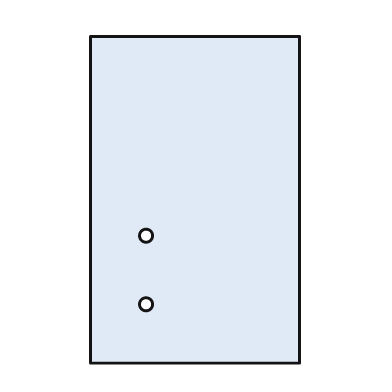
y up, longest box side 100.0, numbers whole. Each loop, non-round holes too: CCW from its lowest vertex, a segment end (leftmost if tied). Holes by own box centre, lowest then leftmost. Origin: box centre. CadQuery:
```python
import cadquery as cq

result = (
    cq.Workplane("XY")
    .moveTo(-32.0, -50.0)
    .lineTo(32.0, -50.0)
    .lineTo(32.0, 50.0)
    .lineTo(-32.0, 50.0)
    .close()
    .moveTo(-15.0, -32.0)
    .circle(2.0)
    .moveTo(-15.0, -11.0)
    .circle(2.0)
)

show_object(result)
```